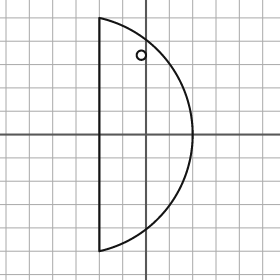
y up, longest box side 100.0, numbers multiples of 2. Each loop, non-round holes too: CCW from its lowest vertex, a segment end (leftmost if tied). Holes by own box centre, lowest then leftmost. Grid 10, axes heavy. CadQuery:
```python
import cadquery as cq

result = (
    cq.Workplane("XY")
    .moveTo(-20.0, -50.0)
    .threePointArc((20.0, 0.0), (-20.0, 50.0))
    .close()
    .moveTo(-2.0, 34.0)
    .circle(2.0)
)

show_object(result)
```